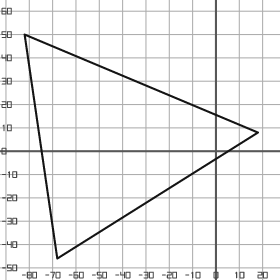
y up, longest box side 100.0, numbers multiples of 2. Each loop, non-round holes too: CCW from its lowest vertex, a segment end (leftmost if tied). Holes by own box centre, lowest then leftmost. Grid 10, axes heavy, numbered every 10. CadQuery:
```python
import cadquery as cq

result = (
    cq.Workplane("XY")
    .moveTo(-68.0, -46.0)
    .lineTo(18.0, 8.0)
    .lineTo(-82.0, 50.0)
    .close()
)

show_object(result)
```